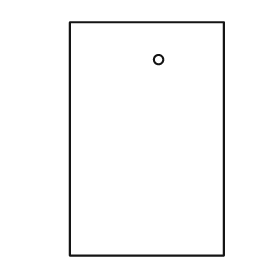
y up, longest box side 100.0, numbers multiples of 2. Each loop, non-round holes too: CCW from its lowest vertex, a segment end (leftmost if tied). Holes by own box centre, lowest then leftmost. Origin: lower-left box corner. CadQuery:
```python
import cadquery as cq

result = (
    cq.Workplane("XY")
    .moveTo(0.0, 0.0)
    .lineTo(66.0, 0.0)
    .lineTo(66.0, 100.0)
    .lineTo(0.0, 100.0)
    .close()
    .moveTo(38.0, 84.0)
    .circle(2.0)
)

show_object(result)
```